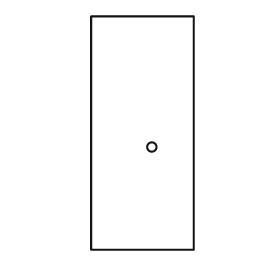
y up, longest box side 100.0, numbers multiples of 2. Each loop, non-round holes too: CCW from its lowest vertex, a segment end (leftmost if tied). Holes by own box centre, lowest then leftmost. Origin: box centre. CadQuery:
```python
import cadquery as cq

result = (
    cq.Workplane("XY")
    .moveTo(-22.0, -50.0)
    .lineTo(22.0, -50.0)
    .lineTo(22.0, 50.0)
    .lineTo(-22.0, 50.0)
    .close()
    .moveTo(4.0, -6.0)
    .circle(2.0)
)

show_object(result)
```